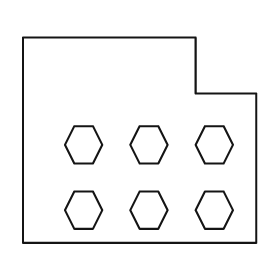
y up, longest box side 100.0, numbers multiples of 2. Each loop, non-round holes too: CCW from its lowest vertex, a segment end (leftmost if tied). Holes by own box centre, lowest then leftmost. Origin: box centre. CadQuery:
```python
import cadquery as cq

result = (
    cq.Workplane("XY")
    .moveTo(-50.0, -44.0)
    .lineTo(50.0, -44.0)
    .lineTo(50.0, 20.0)
    .lineTo(24.0, 20.0)
    .lineTo(24.0, 44.0)
    .lineTo(-50.0, 44.0)
    .close()
    .moveTo(-28.0, -38.0)
    .lineTo(-20.0, -38.0)
    .lineTo(-16.0, -30.0)
    .lineTo(-20.0, -22.0)
    .lineTo(-28.0, -22.0)
    .lineTo(-32.0, -30.0)
    .close()
    .moveTo(0.0, -38.0)
    .lineTo(8.0, -38.0)
    .lineTo(12.0, -30.0)
    .lineTo(8.0, -22.0)
    .lineTo(0.0, -22.0)
    .lineTo(-4.0, -30.0)
    .close()
    .moveTo(28.0, -38.0)
    .lineTo(36.0, -38.0)
    .lineTo(40.0, -30.0)
    .lineTo(36.0, -22.0)
    .lineTo(28.0, -22.0)
    .lineTo(24.0, -30.0)
    .close()
    .moveTo(-28.0, -10.0)
    .lineTo(-20.0, -10.0)
    .lineTo(-16.0, -2.0)
    .lineTo(-20.0, 6.0)
    .lineTo(-28.0, 6.0)
    .lineTo(-32.0, -2.0)
    .close()
    .moveTo(0.0, -10.0)
    .lineTo(8.0, -10.0)
    .lineTo(12.0, -2.0)
    .lineTo(8.0, 6.0)
    .lineTo(0.0, 6.0)
    .lineTo(-4.0, -2.0)
    .close()
    .moveTo(28.0, -10.0)
    .lineTo(36.0, -10.0)
    .lineTo(40.0, -2.0)
    .lineTo(36.0, 6.0)
    .lineTo(28.0, 6.0)
    .lineTo(24.0, -2.0)
    .close()
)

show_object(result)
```